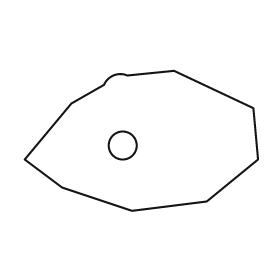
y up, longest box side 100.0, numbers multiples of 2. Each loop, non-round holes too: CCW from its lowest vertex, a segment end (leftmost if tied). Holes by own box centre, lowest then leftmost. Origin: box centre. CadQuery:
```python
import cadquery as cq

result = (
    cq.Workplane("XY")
    .moveTo(-4.0, -30.0)
    .lineTo(28.0, -26.0)
    .lineTo(50.0, -8.0)
    .lineTo(48.0, 14.0)
    .lineTo(14.0, 30.0)
    .lineTo(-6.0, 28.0)
    .threePointArc((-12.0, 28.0), (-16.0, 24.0))
    .lineTo(-30.0, 16.0)
    .lineTo(-50.0, -8.0)
    .lineTo(-34.0, -20.0)
    .close()
    .moveTo(-8.0, -2.0)
    .circle(6.0)
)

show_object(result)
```